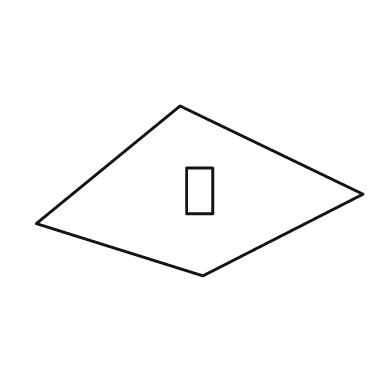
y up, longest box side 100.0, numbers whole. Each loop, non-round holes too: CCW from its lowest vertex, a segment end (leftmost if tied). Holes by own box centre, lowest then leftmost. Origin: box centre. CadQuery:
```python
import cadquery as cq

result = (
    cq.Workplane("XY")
    .moveTo(1.0, -26.0)
    .lineTo(50.0, -1.0)
    .lineTo(-6.0, 26.0)
    .lineTo(-50.0, -10.0)
    .close()
    .moveTo(-4.0, -7.0)
    .lineTo(4.0, -7.0)
    .lineTo(4.0, 7.0)
    .lineTo(-4.0, 7.0)
    .close()
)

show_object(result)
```